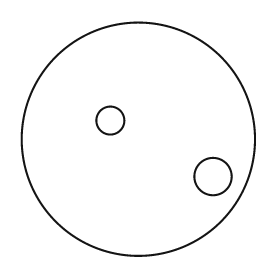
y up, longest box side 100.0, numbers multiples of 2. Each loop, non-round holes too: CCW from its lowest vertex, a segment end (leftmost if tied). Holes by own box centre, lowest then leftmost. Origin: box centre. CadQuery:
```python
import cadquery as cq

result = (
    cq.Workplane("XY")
    .moveTo(0.0, 0.0)
    .circle(50.0)
    .moveTo(32.0, -16.0)
    .circle(8.0)
    .moveTo(-12.0, 8.0)
    .circle(6.0)
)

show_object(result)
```